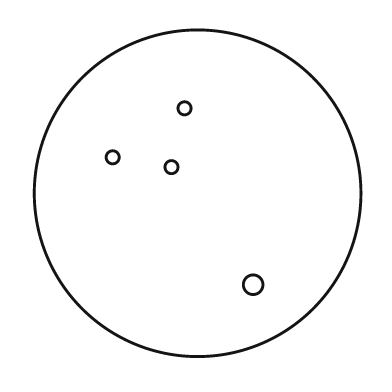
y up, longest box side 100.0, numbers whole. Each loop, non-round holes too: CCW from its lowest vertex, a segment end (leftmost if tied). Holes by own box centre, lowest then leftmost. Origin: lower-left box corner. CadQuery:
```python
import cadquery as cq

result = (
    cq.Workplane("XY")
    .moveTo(50.0, 50.0)
    .circle(50.0)
    .moveTo(67.0, 22.0)
    .circle(3.0)
    .moveTo(42.0, 58.0)
    .circle(2.0)
    .moveTo(24.0, 61.0)
    .circle(2.0)
    .moveTo(46.0, 76.0)
    .circle(2.0)
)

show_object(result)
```